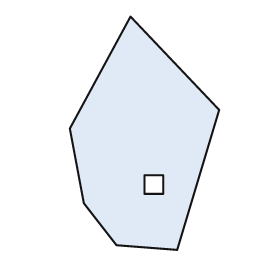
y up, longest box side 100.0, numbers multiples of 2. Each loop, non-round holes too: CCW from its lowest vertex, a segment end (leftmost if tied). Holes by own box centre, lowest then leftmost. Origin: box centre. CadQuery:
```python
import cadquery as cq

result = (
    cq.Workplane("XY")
    .moveTo(14.0, -50.0)
    .lineTo(32.0, 10.0)
    .lineTo(-6.0, 50.0)
    .lineTo(-32.0, 2.0)
    .lineTo(-26.0, -30.0)
    .lineTo(-12.0, -48.0)
    .close()
    .moveTo(0.0, -26.0)
    .lineTo(8.0, -26.0)
    .lineTo(8.0, -18.0)
    .lineTo(0.0, -18.0)
    .close()
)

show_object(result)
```